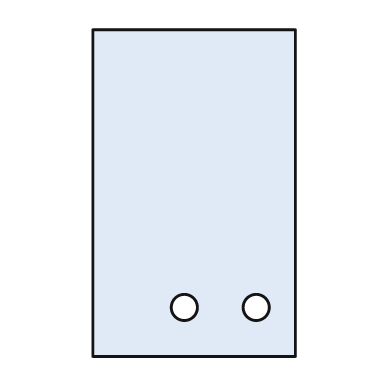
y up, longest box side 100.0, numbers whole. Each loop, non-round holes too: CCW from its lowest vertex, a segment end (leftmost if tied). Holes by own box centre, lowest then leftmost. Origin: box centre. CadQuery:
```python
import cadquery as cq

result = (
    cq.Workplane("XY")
    .moveTo(-31.0, -50.0)
    .lineTo(31.0, -50.0)
    .lineTo(31.0, 50.0)
    .lineTo(-31.0, 50.0)
    .close()
    .moveTo(-3.0, -35.0)
    .circle(4.0)
    .moveTo(19.0, -35.0)
    .circle(4.0)
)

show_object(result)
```